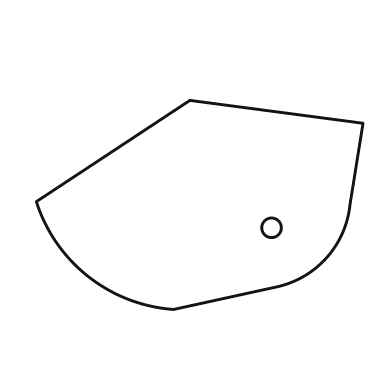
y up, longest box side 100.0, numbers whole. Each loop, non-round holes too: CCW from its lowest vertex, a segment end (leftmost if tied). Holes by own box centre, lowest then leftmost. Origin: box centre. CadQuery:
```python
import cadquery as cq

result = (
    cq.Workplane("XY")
    .moveTo(-8.0, -32.0)
    .lineTo(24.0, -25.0)
    .threePointArc((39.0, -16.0), (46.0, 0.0))
    .lineTo(50.0, 25.0)
    .lineTo(-3.0, 32.0)
    .lineTo(-50.0, 1.0)
    .threePointArc((-34.0, -22.0), (-8.0, -32.0))
    .close()
    .moveTo(22.0, -7.0)
    .circle(3.0)
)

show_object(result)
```